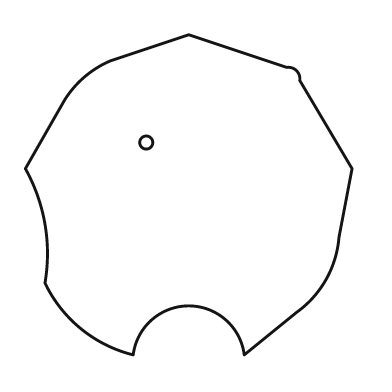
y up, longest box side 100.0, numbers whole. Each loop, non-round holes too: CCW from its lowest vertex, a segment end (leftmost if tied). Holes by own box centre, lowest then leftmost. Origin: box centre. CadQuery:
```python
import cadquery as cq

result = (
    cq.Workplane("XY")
    .moveTo(-17.0, -49.0)
    .threePointArc((0.0, -34.0), (17.0, -49.0))
    .lineTo(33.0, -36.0)
    .threePointArc((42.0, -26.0), (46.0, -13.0))
    .lineTo(50.0, 8.0)
    .lineTo(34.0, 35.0)
    .threePointArc((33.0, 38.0), (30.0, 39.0))
    .lineTo(0.0, 49.0)
    .lineTo(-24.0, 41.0)
    .threePointArc((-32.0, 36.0), (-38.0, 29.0))
    .lineTo(-50.0, 8.0)
    .threePointArc((-44.0, -9.0), (-44.0, -27.0))
    .threePointArc((-33.0, -41.0), (-17.0, -49.0))
    .close()
    .moveTo(-13.0, 16.0)
    .circle(2.0)
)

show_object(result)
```